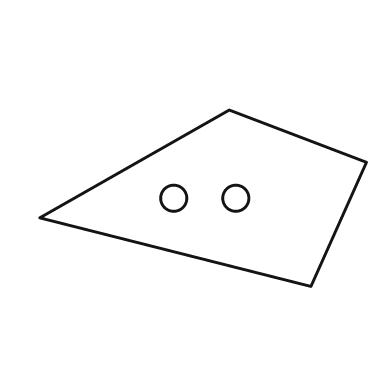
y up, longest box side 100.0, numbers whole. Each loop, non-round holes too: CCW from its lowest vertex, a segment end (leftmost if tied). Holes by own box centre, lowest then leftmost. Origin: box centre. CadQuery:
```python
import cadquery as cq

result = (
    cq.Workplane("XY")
    .moveTo(33.0, -27.0)
    .lineTo(50.0, 11.0)
    .lineTo(8.0, 27.0)
    .lineTo(-50.0, -6.0)
    .close()
    .moveTo(-9.0, 0.0)
    .circle(4.0)
    .moveTo(10.0, 0.0)
    .circle(4.0)
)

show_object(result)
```